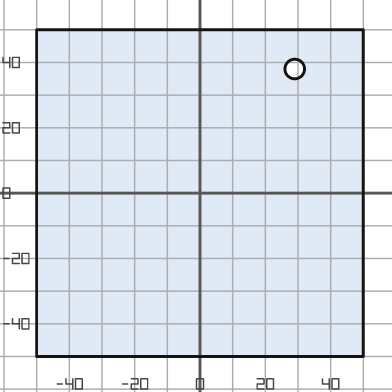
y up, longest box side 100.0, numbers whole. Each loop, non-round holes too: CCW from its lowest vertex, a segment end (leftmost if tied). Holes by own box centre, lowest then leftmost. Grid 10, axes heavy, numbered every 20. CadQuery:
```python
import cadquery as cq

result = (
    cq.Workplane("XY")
    .moveTo(-50.0, -50.0)
    .lineTo(50.0, -50.0)
    .lineTo(50.0, 50.0)
    .lineTo(-50.0, 50.0)
    .close()
    .moveTo(29.0, 38.0)
    .circle(3.0)
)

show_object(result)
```